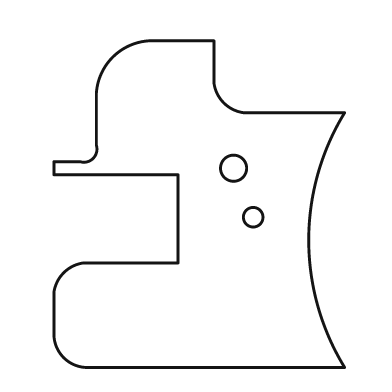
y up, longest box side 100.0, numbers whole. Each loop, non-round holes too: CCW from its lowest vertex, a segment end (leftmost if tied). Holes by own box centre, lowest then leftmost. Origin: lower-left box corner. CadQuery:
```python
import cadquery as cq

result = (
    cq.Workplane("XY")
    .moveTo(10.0, 0.0)
    .lineTo(89.0, 0.0)
    .threePointArc((78.0, 39.0), (89.0, 78.0))
    .lineTo(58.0, 78.0)
    .threePointArc((52.0, 81.0), (49.0, 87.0))
    .lineTo(49.0, 100.0)
    .lineTo(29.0, 100.0)
    .threePointArc((18.0, 95.0), (13.0, 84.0))
    .lineTo(13.0, 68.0)
    .threePointArc((12.0, 64.0), (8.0, 63.0))
    .lineTo(0.0, 63.0)
    .lineTo(0.0, 59.0)
    .lineTo(38.0, 59.0)
    .lineTo(38.0, 32.0)
    .lineTo(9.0, 32.0)
    .threePointArc((3.0, 29.0), (0.0, 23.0))
    .lineTo(0.0, 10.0)
    .threePointArc((3.0, 3.0), (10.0, 0.0))
    .close()
    .moveTo(61.0, 46.0)
    .circle(3.0)
    .moveTo(55.0, 61.0)
    .circle(4.0)
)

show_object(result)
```